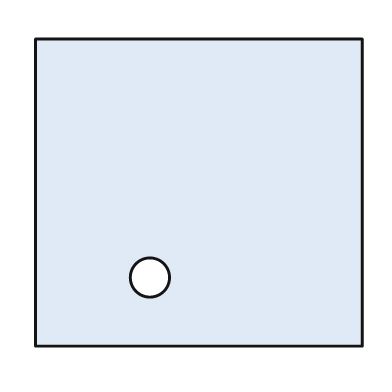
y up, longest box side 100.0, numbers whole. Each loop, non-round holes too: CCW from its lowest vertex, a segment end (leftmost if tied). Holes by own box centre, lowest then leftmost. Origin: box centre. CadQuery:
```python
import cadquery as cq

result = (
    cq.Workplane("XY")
    .moveTo(-50.0, -47.0)
    .lineTo(50.0, -47.0)
    .lineTo(50.0, 47.0)
    .lineTo(-50.0, 47.0)
    .close()
    .moveTo(-15.0, -26.0)
    .circle(6.0)
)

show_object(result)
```